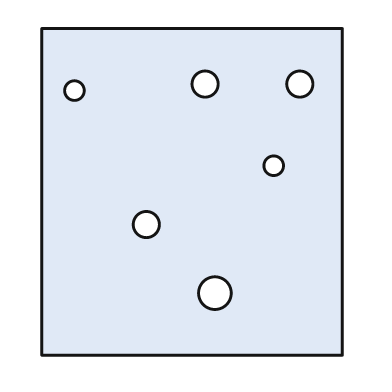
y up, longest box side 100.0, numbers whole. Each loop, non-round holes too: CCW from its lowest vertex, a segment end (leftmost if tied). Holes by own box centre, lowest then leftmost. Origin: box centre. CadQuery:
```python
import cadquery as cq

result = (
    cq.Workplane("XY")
    .moveTo(-46.0, -50.0)
    .lineTo(46.0, -50.0)
    .lineTo(46.0, 50.0)
    .lineTo(-46.0, 50.0)
    .close()
    .moveTo(7.0, -31.0)
    .circle(5.0)
    .moveTo(-14.0, -10.0)
    .circle(4.0)
    .moveTo(25.0, 8.0)
    .circle(3.0)
    .moveTo(-36.0, 31.0)
    .circle(3.0)
    .moveTo(4.0, 33.0)
    .circle(4.0)
    .moveTo(33.0, 33.0)
    .circle(4.0)
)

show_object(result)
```